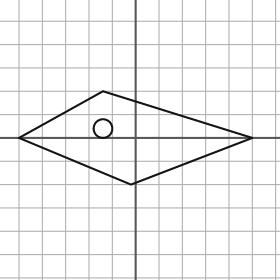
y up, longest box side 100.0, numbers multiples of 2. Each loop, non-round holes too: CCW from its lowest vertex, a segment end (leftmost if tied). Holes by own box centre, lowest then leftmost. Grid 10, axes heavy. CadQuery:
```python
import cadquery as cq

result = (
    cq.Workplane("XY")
    .moveTo(-2.0, -20.0)
    .lineTo(50.0, 0.0)
    .lineTo(-14.0, 20.0)
    .lineTo(-50.0, 0.0)
    .close()
    .moveTo(-14.0, 4.0)
    .circle(4.0)
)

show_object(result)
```